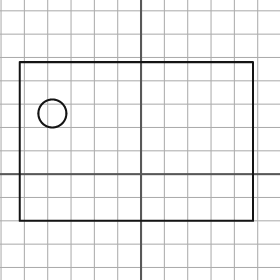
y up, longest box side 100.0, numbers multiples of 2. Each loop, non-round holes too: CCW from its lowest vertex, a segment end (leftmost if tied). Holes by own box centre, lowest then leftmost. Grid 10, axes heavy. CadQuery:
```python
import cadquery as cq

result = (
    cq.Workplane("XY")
    .moveTo(-52.0, -20.0)
    .lineTo(48.0, -20.0)
    .lineTo(48.0, 48.0)
    .lineTo(-52.0, 48.0)
    .close()
    .moveTo(-38.0, 26.0)
    .circle(6.0)
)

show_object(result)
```